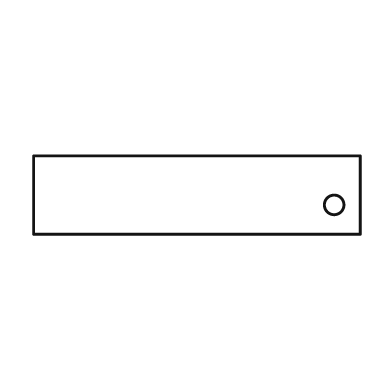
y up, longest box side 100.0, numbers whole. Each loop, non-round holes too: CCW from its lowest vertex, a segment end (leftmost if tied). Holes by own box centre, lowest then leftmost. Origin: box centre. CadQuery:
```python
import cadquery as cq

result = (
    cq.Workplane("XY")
    .moveTo(-50.0, -12.0)
    .lineTo(50.0, -12.0)
    .lineTo(50.0, 12.0)
    .lineTo(-50.0, 12.0)
    .close()
    .moveTo(42.0, -3.0)
    .circle(3.0)
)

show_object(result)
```